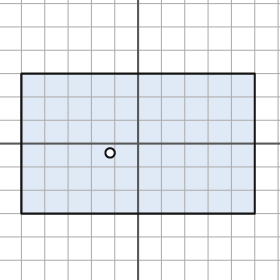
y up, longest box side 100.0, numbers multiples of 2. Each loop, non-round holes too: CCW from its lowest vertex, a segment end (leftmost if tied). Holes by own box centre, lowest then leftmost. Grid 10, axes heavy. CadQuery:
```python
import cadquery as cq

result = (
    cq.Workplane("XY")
    .moveTo(-50.0, -30.0)
    .lineTo(50.0, -30.0)
    .lineTo(50.0, 30.0)
    .lineTo(-50.0, 30.0)
    .close()
    .moveTo(-12.0, -4.0)
    .circle(2.0)
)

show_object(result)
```